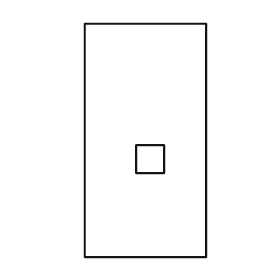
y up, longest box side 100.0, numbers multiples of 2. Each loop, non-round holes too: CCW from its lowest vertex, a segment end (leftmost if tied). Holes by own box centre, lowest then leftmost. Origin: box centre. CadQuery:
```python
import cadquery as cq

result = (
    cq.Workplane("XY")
    .moveTo(-26.0, -50.0)
    .lineTo(26.0, -50.0)
    .lineTo(26.0, 50.0)
    .lineTo(-26.0, 50.0)
    .close()
    .moveTo(-4.0, -14.0)
    .lineTo(8.0, -14.0)
    .lineTo(8.0, -2.0)
    .lineTo(-4.0, -2.0)
    .close()
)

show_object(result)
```